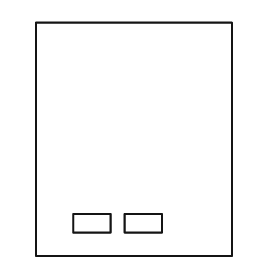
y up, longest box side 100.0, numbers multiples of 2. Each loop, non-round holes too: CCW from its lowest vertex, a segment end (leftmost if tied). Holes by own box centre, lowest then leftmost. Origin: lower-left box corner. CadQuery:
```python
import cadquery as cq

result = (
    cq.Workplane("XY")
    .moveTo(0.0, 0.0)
    .lineTo(84.0, 0.0)
    .lineTo(84.0, 100.0)
    .lineTo(0.0, 100.0)
    .close()
    .moveTo(16.0, 10.0)
    .lineTo(32.0, 10.0)
    .lineTo(32.0, 18.0)
    .lineTo(16.0, 18.0)
    .close()
    .moveTo(38.0, 10.0)
    .lineTo(54.0, 10.0)
    .lineTo(54.0, 18.0)
    .lineTo(38.0, 18.0)
    .close()
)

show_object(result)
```